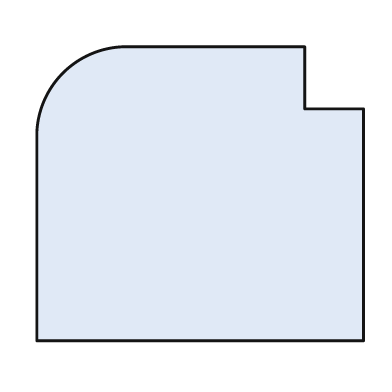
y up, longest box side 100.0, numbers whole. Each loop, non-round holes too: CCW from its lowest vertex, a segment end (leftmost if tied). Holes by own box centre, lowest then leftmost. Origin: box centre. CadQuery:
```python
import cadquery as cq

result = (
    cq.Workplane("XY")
    .moveTo(-50.0, -45.0)
    .lineTo(50.0, -45.0)
    .lineTo(50.0, 26.0)
    .lineTo(32.0, 26.0)
    .lineTo(32.0, 45.0)
    .lineTo(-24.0, 45.0)
    .threePointArc((-42.0, 37.0), (-50.0, 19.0))
    .close()
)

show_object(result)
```